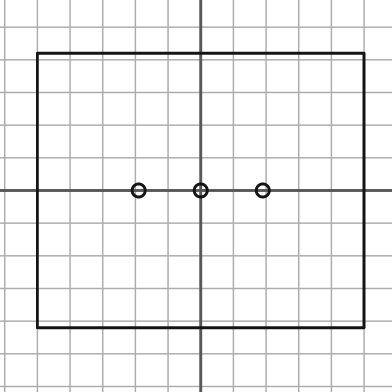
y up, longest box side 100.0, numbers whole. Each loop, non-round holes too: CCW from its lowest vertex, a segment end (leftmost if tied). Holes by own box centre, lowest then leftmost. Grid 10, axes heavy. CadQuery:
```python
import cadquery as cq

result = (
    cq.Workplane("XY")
    .moveTo(-50.0, -42.0)
    .lineTo(50.0, -42.0)
    .lineTo(50.0, 42.0)
    .lineTo(-50.0, 42.0)
    .close()
    .moveTo(-19.0, 0.0)
    .circle(2.0)
    .moveTo(0.0, 0.0)
    .circle(2.0)
    .moveTo(19.0, 0.0)
    .circle(2.0)
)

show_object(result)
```